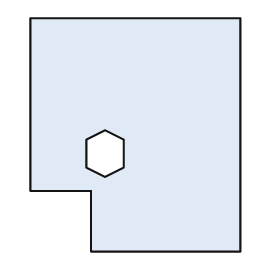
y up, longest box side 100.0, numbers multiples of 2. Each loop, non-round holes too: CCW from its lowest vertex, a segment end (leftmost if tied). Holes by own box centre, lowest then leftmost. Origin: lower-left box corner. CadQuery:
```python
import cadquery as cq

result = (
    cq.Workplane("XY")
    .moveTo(26.0, 0.0)
    .lineTo(90.0, 0.0)
    .lineTo(90.0, 100.0)
    .lineTo(0.0, 100.0)
    .lineTo(0.0, 26.0)
    .lineTo(26.0, 26.0)
    .close()
    .moveTo(32.0, 32.0)
    .lineTo(40.0, 36.0)
    .lineTo(40.0, 48.0)
    .lineTo(32.0, 52.0)
    .lineTo(24.0, 48.0)
    .lineTo(24.0, 36.0)
    .close()
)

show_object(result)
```